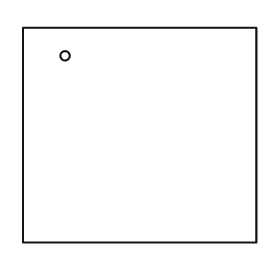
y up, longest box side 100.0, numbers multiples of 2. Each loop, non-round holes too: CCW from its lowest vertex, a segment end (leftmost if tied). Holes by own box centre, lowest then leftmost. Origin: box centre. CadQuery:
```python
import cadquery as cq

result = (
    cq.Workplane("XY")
    .moveTo(-50.0, -46.0)
    .lineTo(50.0, -46.0)
    .lineTo(50.0, 46.0)
    .lineTo(-50.0, 46.0)
    .close()
    .moveTo(-32.0, 34.0)
    .circle(2.0)
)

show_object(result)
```